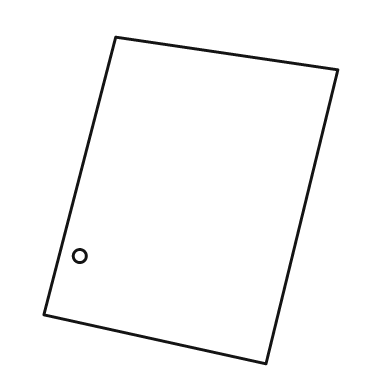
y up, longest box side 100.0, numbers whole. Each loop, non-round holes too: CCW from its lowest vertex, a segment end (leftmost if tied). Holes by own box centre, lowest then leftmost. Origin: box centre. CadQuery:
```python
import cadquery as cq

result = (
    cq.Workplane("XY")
    .moveTo(23.0, -50.0)
    .lineTo(45.0, 40.0)
    .lineTo(-23.0, 50.0)
    .lineTo(-45.0, -35.0)
    .close()
    .moveTo(-34.0, -17.0)
    .circle(2.0)
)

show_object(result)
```